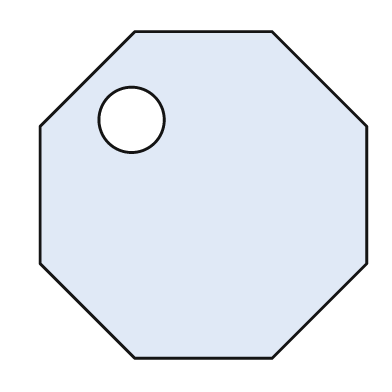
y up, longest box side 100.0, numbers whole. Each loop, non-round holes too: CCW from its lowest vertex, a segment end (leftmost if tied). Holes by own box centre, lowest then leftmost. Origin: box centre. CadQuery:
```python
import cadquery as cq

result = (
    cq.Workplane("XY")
    .moveTo(-21.0, -50.0)
    .lineTo(21.0, -50.0)
    .lineTo(50.0, -21.0)
    .lineTo(50.0, 21.0)
    .lineTo(21.0, 50.0)
    .lineTo(-21.0, 50.0)
    .lineTo(-50.0, 21.0)
    .lineTo(-50.0, -21.0)
    .close()
    .moveTo(-22.0, 23.0)
    .circle(10.0)
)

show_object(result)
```